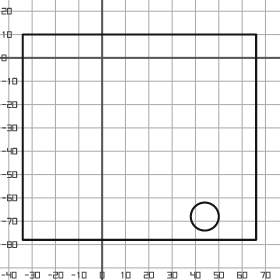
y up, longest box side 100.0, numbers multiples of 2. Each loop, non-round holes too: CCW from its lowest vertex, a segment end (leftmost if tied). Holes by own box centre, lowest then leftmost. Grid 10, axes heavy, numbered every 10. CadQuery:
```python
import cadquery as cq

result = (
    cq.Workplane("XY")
    .moveTo(-34.0, -78.0)
    .lineTo(66.0, -78.0)
    .lineTo(66.0, 10.0)
    .lineTo(-34.0, 10.0)
    .close()
    .moveTo(44.0, -68.0)
    .circle(6.0)
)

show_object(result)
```